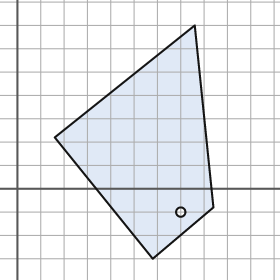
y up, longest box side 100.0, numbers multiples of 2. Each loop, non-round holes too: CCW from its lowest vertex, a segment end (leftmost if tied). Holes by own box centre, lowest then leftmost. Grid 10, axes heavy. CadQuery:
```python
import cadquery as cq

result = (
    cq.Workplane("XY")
    .moveTo(58.0, -30.0)
    .lineTo(84.0, -8.0)
    .lineTo(76.0, 70.0)
    .lineTo(16.0, 22.0)
    .close()
    .moveTo(70.0, -10.0)
    .circle(2.0)
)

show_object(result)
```